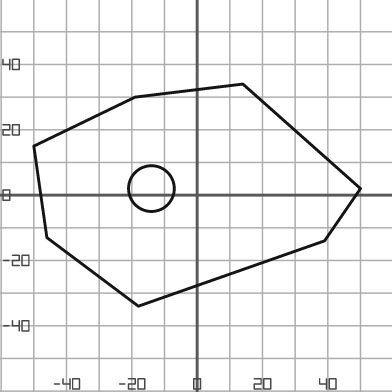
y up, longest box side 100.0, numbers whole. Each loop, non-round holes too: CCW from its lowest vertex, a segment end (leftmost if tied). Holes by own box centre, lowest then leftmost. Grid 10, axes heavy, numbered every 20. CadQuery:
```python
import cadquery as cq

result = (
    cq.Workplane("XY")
    .moveTo(-18.0, -34.0)
    .lineTo(39.0, -14.0)
    .lineTo(50.0, 2.0)
    .lineTo(14.0, 34.0)
    .lineTo(-19.0, 30.0)
    .lineTo(-50.0, 15.0)
    .lineTo(-46.0, -13.0)
    .close()
    .moveTo(-14.0, 2.0)
    .circle(7.0)
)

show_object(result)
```